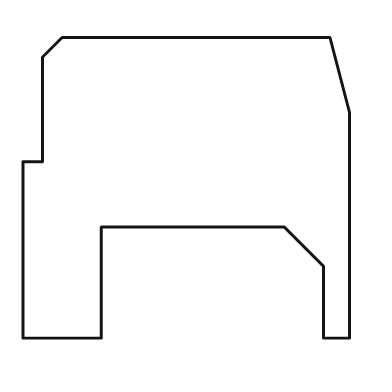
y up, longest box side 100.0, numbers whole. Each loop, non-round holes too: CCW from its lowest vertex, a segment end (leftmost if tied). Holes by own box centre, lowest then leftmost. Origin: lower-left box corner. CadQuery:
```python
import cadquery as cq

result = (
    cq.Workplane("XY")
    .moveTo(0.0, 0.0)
    .lineTo(24.0, 0.0)
    .lineTo(24.0, 34.0)
    .lineTo(80.0, 34.0)
    .lineTo(92.0, 22.0)
    .lineTo(92.0, 0.0)
    .lineTo(100.0, 0.0)
    .lineTo(100.0, 69.0)
    .lineTo(94.0, 92.0)
    .lineTo(12.0, 92.0)
    .lineTo(6.0, 86.0)
    .lineTo(6.0, 54.0)
    .lineTo(0.0, 54.0)
    .close()
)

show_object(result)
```